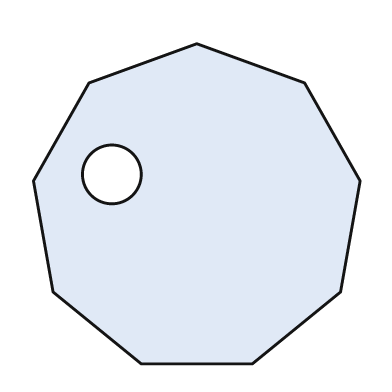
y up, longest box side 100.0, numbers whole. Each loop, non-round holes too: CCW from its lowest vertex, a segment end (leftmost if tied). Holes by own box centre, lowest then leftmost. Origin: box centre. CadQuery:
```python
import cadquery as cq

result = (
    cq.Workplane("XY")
    .moveTo(-17.0, -49.0)
    .lineTo(17.0, -49.0)
    .lineTo(44.0, -27.0)
    .lineTo(50.0, 7.0)
    .lineTo(33.0, 37.0)
    .lineTo(0.0, 49.0)
    .lineTo(-33.0, 37.0)
    .lineTo(-50.0, 7.0)
    .lineTo(-44.0, -27.0)
    .close()
    .moveTo(-26.0, 9.0)
    .circle(9.0)
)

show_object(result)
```